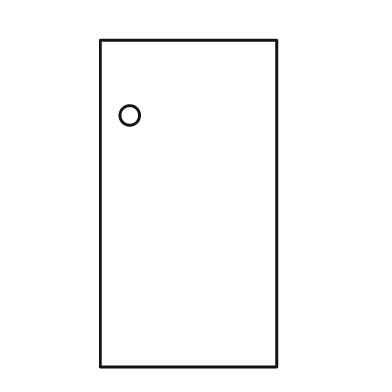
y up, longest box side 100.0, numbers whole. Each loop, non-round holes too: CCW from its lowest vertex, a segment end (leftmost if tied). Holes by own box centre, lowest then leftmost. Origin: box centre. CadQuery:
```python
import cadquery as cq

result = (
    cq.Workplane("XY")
    .moveTo(-27.0, -50.0)
    .lineTo(27.0, -50.0)
    .lineTo(27.0, 50.0)
    .lineTo(-27.0, 50.0)
    .close()
    .moveTo(-18.0, 27.0)
    .circle(3.0)
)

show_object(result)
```